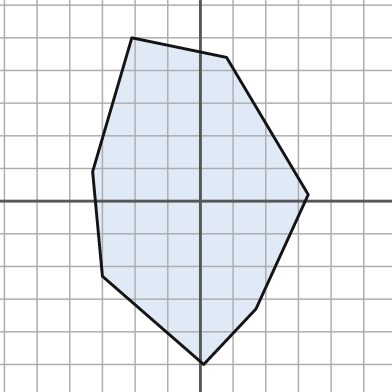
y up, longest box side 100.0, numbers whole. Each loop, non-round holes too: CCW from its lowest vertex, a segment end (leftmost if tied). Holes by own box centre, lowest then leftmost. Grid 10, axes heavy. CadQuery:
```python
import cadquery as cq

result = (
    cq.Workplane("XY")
    .moveTo(1.0, -50.0)
    .lineTo(17.0, -33.0)
    .lineTo(33.0, 2.0)
    .lineTo(8.0, 44.0)
    .lineTo(-21.0, 50.0)
    .lineTo(-33.0, 9.0)
    .lineTo(-30.0, -23.0)
    .close()
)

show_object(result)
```